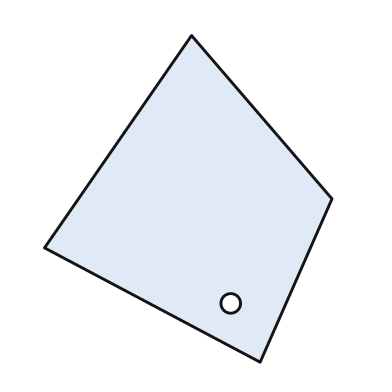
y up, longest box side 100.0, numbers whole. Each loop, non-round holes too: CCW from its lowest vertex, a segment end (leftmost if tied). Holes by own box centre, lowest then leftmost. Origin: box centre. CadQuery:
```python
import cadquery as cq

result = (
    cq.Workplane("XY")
    .moveTo(22.0, -50.0)
    .lineTo(44.0, 0.0)
    .lineTo(1.0, 50.0)
    .lineTo(-44.0, -15.0)
    .close()
    .moveTo(13.0, -32.0)
    .circle(3.0)
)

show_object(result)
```